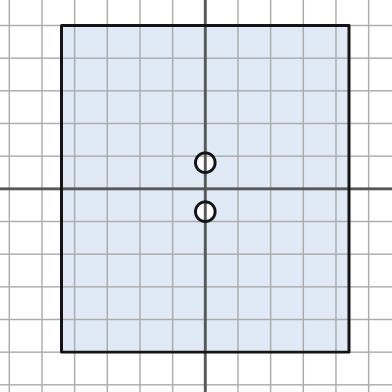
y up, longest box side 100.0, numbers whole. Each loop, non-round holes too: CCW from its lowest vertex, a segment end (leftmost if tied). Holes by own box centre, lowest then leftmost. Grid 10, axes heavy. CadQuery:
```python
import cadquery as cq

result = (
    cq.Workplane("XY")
    .moveTo(-44.0, -50.0)
    .lineTo(44.0, -50.0)
    .lineTo(44.0, 50.0)
    .lineTo(-44.0, 50.0)
    .close()
    .moveTo(0.0, -7.0)
    .circle(3.0)
    .moveTo(0.0, 8.0)
    .circle(3.0)
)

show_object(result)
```